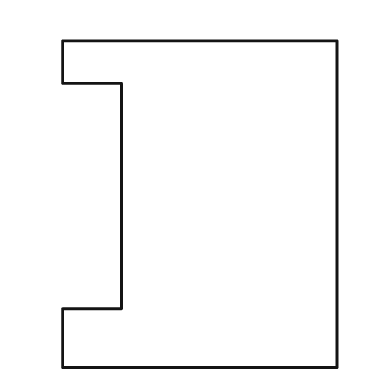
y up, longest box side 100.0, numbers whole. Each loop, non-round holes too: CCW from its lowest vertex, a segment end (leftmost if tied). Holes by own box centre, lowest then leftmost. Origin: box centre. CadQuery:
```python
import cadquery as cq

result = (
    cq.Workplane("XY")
    .moveTo(-42.0, -50.0)
    .lineTo(42.0, -50.0)
    .lineTo(42.0, 50.0)
    .lineTo(-42.0, 50.0)
    .lineTo(-42.0, 37.0)
    .lineTo(-24.0, 37.0)
    .lineTo(-24.0, -32.0)
    .lineTo(-42.0, -32.0)
    .close()
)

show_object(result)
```